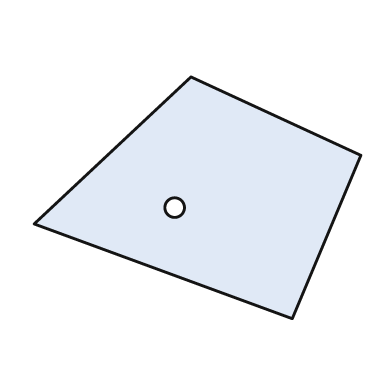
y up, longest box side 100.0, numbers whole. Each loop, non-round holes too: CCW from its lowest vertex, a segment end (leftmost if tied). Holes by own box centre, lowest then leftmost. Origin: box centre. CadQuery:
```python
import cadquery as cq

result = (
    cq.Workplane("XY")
    .moveTo(29.0, -37.0)
    .lineTo(50.0, 13.0)
    .lineTo(-2.0, 37.0)
    .lineTo(-50.0, -8.0)
    .close()
    .moveTo(-7.0, -3.0)
    .circle(3.0)
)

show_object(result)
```